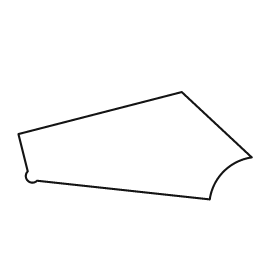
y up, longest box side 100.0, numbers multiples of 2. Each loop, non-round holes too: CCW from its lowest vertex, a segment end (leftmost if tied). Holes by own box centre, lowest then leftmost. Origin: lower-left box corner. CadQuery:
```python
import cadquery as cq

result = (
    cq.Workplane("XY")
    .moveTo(82.0, 0.0)
    .threePointArc((88.0, 12.0), (100.0, 18.0))
    .lineTo(70.0, 46.0)
    .lineTo(0.0, 28.0)
    .lineTo(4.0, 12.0)
    .threePointArc((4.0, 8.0), (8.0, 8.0))
    .close()
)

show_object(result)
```